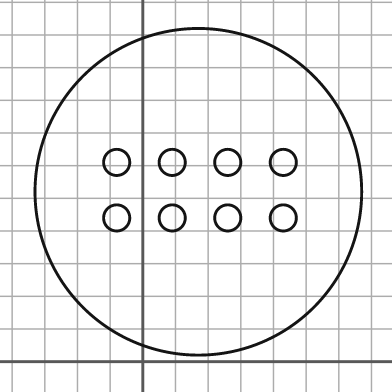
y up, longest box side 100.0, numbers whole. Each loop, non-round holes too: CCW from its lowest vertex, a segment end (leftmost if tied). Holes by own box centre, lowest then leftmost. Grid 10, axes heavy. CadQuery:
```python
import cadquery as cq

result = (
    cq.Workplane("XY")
    .moveTo(17.0, 52.0)
    .circle(50.0)
    .moveTo(-8.0, 44.0)
    .circle(4.0)
    .moveTo(9.0, 44.0)
    .circle(4.0)
    .moveTo(26.0, 44.0)
    .circle(4.0)
    .moveTo(43.0, 44.0)
    .circle(4.0)
    .moveTo(-8.0, 61.0)
    .circle(4.0)
    .moveTo(9.0, 61.0)
    .circle(4.0)
    .moveTo(26.0, 61.0)
    .circle(4.0)
    .moveTo(43.0, 61.0)
    .circle(4.0)
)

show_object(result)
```